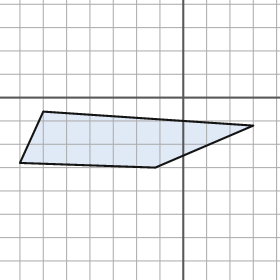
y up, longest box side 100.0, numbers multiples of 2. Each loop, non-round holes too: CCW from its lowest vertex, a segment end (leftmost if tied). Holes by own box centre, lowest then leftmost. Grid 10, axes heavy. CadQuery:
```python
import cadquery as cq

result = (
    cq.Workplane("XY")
    .moveTo(-12.0, -30.0)
    .lineTo(30.0, -12.0)
    .lineTo(-60.0, -6.0)
    .lineTo(-70.0, -28.0)
    .close()
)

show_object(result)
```